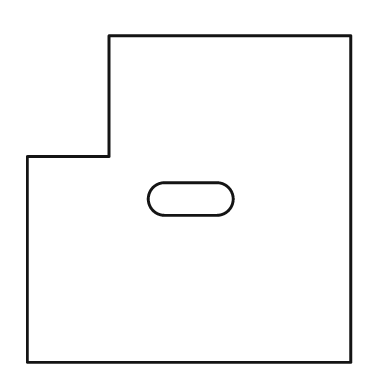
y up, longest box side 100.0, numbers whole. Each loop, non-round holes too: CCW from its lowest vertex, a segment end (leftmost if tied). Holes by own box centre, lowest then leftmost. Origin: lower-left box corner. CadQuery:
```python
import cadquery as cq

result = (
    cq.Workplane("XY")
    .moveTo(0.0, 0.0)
    .lineTo(99.0, 0.0)
    .lineTo(99.0, 100.0)
    .lineTo(25.0, 100.0)
    .lineTo(25.0, 63.0)
    .lineTo(0.0, 63.0)
    .close()
    .moveTo(42.0, 45.0)
    .lineTo(58.0, 45.0)
    .threePointArc((63.0, 50.0), (58.0, 55.0))
    .lineTo(42.0, 55.0)
    .threePointArc((37.0, 50.0), (42.0, 45.0))
    .close()
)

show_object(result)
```